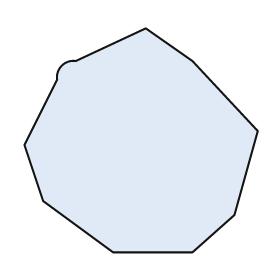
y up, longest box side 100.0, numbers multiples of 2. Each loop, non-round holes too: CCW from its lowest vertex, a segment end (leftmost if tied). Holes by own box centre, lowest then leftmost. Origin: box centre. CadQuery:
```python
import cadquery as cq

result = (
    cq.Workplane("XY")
    .moveTo(-12.0, -48.0)
    .lineTo(22.0, -48.0)
    .lineTo(40.0, -32.0)
    .lineTo(50.0, 4.0)
    .lineTo(22.0, 34.0)
    .lineTo(2.0, 48.0)
    .lineTo(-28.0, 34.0)
    .threePointArc((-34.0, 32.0), (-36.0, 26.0))
    .lineTo(-50.0, -2.0)
    .lineTo(-42.0, -26.0)
    .close()
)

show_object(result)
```